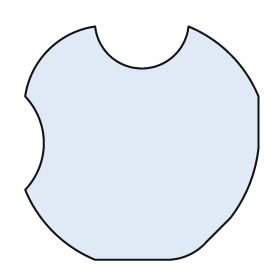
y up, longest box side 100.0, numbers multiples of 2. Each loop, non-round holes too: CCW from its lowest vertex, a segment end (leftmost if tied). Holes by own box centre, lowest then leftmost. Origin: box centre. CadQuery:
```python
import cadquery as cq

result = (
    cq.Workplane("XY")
    .moveTo(-20.0, -50.0)
    .lineTo(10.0, -50.0)
    .threePointArc((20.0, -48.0), (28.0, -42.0))
    .lineTo(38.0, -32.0)
    .threePointArc((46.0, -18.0), (50.0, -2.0))
    .lineTo(50.0, 20.0)
    .threePointArc((38.0, 38.0), (20.0, 50.0))
    .threePointArc((0.0, 32.0), (-20.0, 50.0))
    .threePointArc((-40.0, 40.0), (-50.0, 20.0))
    .threePointArc((-42.0, 0.0), (-50.0, -20.0))
    .threePointArc((-38.0, -38.0), (-20.0, -50.0))
    .close()
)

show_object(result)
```